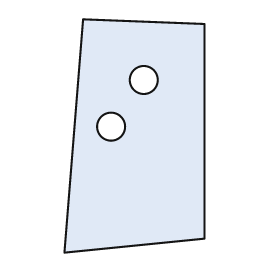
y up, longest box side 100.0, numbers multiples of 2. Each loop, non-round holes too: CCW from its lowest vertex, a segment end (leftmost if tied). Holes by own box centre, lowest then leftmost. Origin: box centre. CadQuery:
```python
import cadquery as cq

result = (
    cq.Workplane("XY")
    .moveTo(-30.0, -50.0)
    .lineTo(30.0, -44.0)
    .lineTo(30.0, 48.0)
    .lineTo(-22.0, 50.0)
    .close()
    .moveTo(-10.0, 4.0)
    .circle(6.0)
    .moveTo(4.0, 24.0)
    .circle(6.0)
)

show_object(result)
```